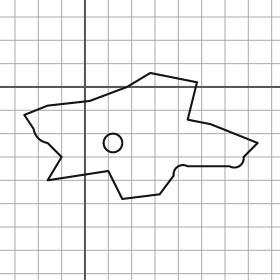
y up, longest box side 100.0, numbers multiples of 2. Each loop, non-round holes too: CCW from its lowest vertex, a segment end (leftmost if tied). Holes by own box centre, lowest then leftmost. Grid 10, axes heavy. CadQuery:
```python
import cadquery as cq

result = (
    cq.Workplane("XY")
    .moveTo(16.0, -48.0)
    .lineTo(32.0, -46.0)
    .lineTo(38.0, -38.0)
    .threePointArc((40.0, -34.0), (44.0, -34.0))
    .lineTo(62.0, -34.0)
    .threePointArc((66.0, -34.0), (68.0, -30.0))
    .lineTo(74.0, -24.0)
    .lineTo(54.0, -16.0)
    .lineTo(44.0, -14.0)
    .lineTo(48.0, 2.0)
    .lineTo(28.0, 6.0)
    .lineTo(18.0, 0.0)
    .lineTo(2.0, -6.0)
    .lineTo(-16.0, -8.0)
    .lineTo(-26.0, -12.0)
    .lineTo(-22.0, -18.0)
    .threePointArc((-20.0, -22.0), (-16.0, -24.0))
    .lineTo(-10.0, -30.0)
    .lineTo(-16.0, -40.0)
    .lineTo(10.0, -36.0)
    .close()
    .moveTo(12.0, -24.0)
    .circle(4.0)
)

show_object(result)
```